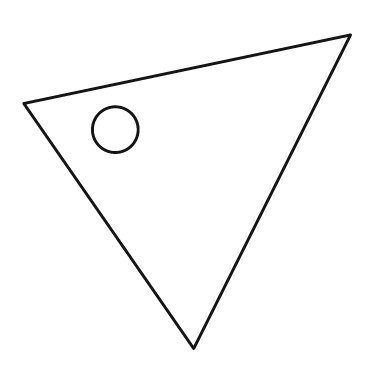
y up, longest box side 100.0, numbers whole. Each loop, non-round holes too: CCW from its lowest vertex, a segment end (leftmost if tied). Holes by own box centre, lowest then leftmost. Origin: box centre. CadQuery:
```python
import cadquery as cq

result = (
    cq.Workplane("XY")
    .moveTo(2.0, -48.0)
    .lineTo(50.0, 48.0)
    .lineTo(-50.0, 27.0)
    .close()
    .moveTo(-22.0, 19.0)
    .circle(7.0)
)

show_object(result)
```